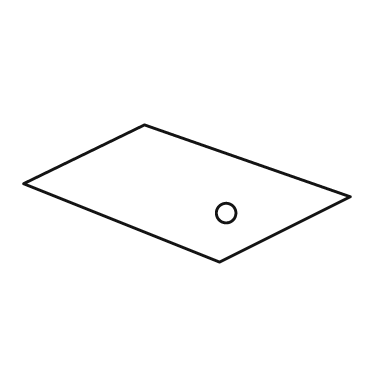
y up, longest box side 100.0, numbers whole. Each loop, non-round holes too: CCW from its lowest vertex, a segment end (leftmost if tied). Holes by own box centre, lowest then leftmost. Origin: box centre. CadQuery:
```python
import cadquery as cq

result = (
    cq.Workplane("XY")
    .moveTo(10.0, -21.0)
    .lineTo(50.0, -1.0)
    .lineTo(-13.0, 21.0)
    .lineTo(-50.0, 3.0)
    .close()
    .moveTo(12.0, -6.0)
    .circle(3.0)
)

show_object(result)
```